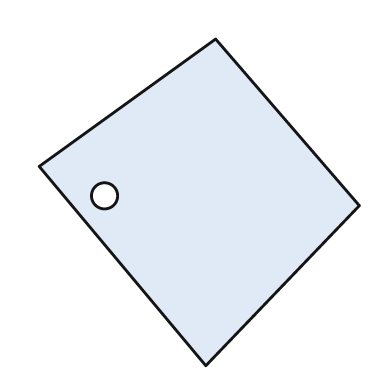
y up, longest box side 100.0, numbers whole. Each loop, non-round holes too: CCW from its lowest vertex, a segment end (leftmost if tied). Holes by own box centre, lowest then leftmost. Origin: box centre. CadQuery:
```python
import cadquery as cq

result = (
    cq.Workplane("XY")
    .moveTo(2.0, -50.0)
    .lineTo(49.0, -1.0)
    .lineTo(5.0, 50.0)
    .lineTo(-49.0, 11.0)
    .close()
    .moveTo(-29.0, 2.0)
    .circle(4.0)
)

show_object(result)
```